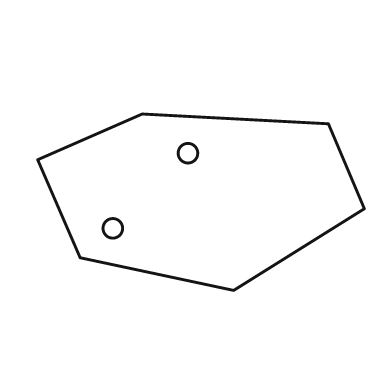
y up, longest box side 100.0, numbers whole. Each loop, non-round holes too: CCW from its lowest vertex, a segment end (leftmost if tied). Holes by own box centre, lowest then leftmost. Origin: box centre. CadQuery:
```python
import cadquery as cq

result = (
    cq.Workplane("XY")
    .moveTo(10.0, -27.0)
    .lineTo(50.0, -2.0)
    .lineTo(39.0, 24.0)
    .lineTo(-18.0, 27.0)
    .lineTo(-50.0, 13.0)
    .lineTo(-37.0, -17.0)
    .close()
    .moveTo(-27.0, -8.0)
    .circle(3.0)
    .moveTo(-4.0, 15.0)
    .circle(3.0)
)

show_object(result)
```